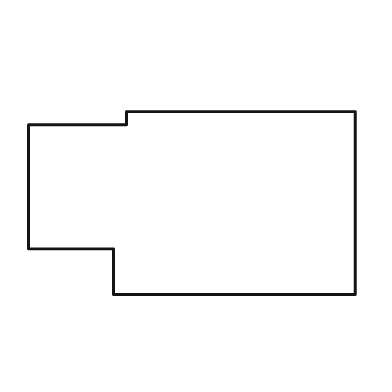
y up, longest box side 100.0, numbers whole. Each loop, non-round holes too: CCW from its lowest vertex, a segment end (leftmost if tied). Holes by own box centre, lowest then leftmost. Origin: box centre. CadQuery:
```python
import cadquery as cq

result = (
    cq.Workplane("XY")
    .moveTo(-24.0, -28.0)
    .lineTo(50.0, -28.0)
    .lineTo(50.0, 28.0)
    .lineTo(-20.0, 28.0)
    .lineTo(-20.0, 24.0)
    .lineTo(-50.0, 24.0)
    .lineTo(-50.0, -14.0)
    .lineTo(-24.0, -14.0)
    .close()
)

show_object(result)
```